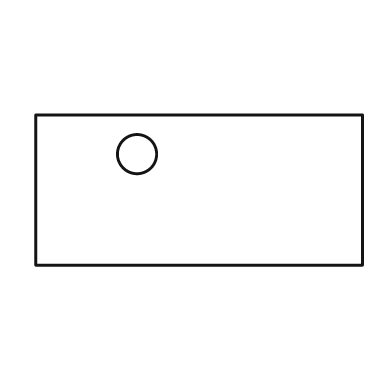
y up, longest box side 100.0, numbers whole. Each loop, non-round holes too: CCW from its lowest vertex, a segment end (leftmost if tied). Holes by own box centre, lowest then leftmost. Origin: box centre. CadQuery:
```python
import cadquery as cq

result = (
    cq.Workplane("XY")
    .moveTo(-50.0, -23.0)
    .lineTo(50.0, -23.0)
    .lineTo(50.0, 23.0)
    .lineTo(-50.0, 23.0)
    .close()
    .moveTo(-19.0, 11.0)
    .circle(6.0)
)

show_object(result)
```